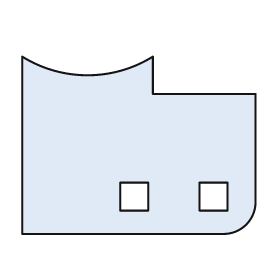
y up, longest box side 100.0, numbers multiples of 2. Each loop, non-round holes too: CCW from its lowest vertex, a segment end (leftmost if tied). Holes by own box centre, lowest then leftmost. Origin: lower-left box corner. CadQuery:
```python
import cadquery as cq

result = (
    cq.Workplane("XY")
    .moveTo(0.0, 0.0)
    .lineTo(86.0, 0.0)
    .threePointArc((96.0, 4.0), (100.0, 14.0))
    .lineTo(100.0, 60.0)
    .lineTo(56.0, 60.0)
    .lineTo(56.0, 76.0)
    .threePointArc((28.0, 68.0), (0.0, 76.0))
    .close()
    .moveTo(42.0, 10.0)
    .lineTo(54.0, 10.0)
    .lineTo(54.0, 22.0)
    .lineTo(42.0, 22.0)
    .close()
    .moveTo(76.0, 10.0)
    .lineTo(88.0, 10.0)
    .lineTo(88.0, 22.0)
    .lineTo(76.0, 22.0)
    .close()
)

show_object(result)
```